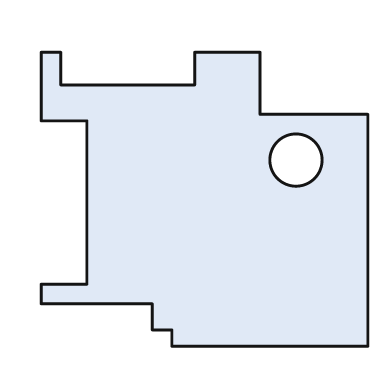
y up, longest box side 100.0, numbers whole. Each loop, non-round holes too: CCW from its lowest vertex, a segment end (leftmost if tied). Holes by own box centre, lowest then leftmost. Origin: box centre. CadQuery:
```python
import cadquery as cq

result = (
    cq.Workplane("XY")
    .moveTo(-10.0, -45.0)
    .lineTo(50.0, -45.0)
    .lineTo(50.0, 26.0)
    .lineTo(17.0, 26.0)
    .lineTo(17.0, 45.0)
    .lineTo(-3.0, 45.0)
    .lineTo(-3.0, 35.0)
    .lineTo(-44.0, 35.0)
    .lineTo(-44.0, 45.0)
    .lineTo(-50.0, 45.0)
    .lineTo(-50.0, 24.0)
    .lineTo(-36.0, 24.0)
    .lineTo(-36.0, -26.0)
    .lineTo(-50.0, -26.0)
    .lineTo(-50.0, -32.0)
    .lineTo(-16.0, -32.0)
    .lineTo(-16.0, -40.0)
    .lineTo(-10.0, -40.0)
    .close()
    .moveTo(28.0, 12.0)
    .circle(8.0)
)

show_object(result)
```